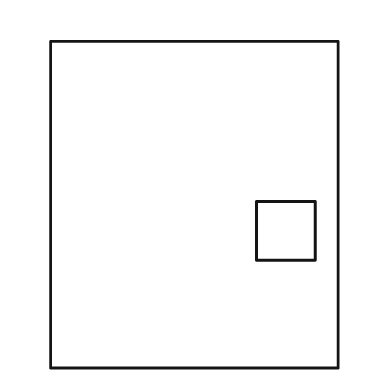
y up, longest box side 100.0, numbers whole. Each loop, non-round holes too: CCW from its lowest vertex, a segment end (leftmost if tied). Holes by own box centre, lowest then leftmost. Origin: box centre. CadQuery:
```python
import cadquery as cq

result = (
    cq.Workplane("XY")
    .moveTo(-44.0, -50.0)
    .lineTo(44.0, -50.0)
    .lineTo(44.0, 50.0)
    .lineTo(-44.0, 50.0)
    .close()
    .moveTo(19.0, -17.0)
    .lineTo(37.0, -17.0)
    .lineTo(37.0, 1.0)
    .lineTo(19.0, 1.0)
    .close()
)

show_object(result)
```